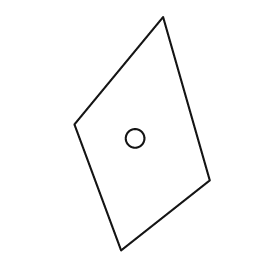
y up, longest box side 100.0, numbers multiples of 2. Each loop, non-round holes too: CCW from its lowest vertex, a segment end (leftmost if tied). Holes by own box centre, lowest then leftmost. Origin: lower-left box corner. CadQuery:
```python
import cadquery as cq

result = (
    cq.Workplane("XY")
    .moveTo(20.0, 0.0)
    .lineTo(58.0, 30.0)
    .lineTo(38.0, 100.0)
    .lineTo(0.0, 54.0)
    .close()
    .moveTo(26.0, 48.0)
    .circle(4.0)
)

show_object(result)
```